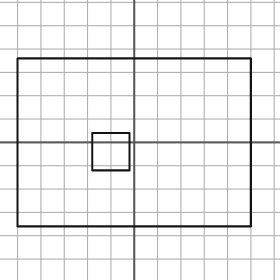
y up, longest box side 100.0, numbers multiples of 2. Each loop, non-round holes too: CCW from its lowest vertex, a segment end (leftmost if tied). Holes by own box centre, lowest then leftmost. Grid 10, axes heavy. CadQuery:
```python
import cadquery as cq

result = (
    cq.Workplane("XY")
    .moveTo(-50.0, -36.0)
    .lineTo(50.0, -36.0)
    .lineTo(50.0, 36.0)
    .lineTo(-50.0, 36.0)
    .close()
    .moveTo(-18.0, -12.0)
    .lineTo(-2.0, -12.0)
    .lineTo(-2.0, 4.0)
    .lineTo(-18.0, 4.0)
    .close()
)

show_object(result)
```